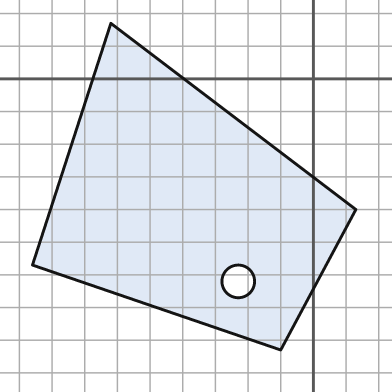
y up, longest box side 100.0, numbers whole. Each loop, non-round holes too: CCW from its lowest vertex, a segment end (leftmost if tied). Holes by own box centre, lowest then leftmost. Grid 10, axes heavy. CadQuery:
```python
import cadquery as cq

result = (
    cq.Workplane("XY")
    .moveTo(-10.0, -83.0)
    .lineTo(13.0, -40.0)
    .lineTo(-62.0, 17.0)
    .lineTo(-86.0, -57.0)
    .close()
    .moveTo(-23.0, -62.0)
    .circle(5.0)
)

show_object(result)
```